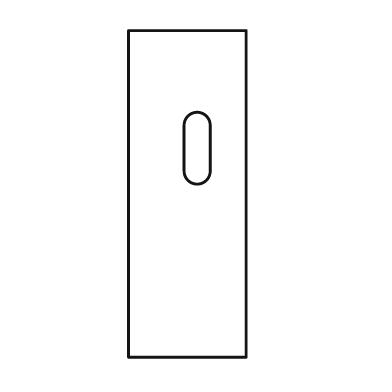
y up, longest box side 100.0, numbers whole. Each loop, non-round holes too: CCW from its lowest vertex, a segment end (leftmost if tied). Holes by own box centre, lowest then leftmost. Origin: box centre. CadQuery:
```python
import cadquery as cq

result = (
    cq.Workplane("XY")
    .moveTo(-18.0, -50.0)
    .lineTo(18.0, -50.0)
    .lineTo(18.0, 50.0)
    .lineTo(-18.0, 50.0)
    .close()
    .moveTo(-1.0, 7.0)
    .threePointArc((3.0, 3.0), (7.0, 7.0))
    .lineTo(7.0, 21.0)
    .threePointArc((3.0, 25.0), (-1.0, 21.0))
    .close()
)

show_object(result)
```